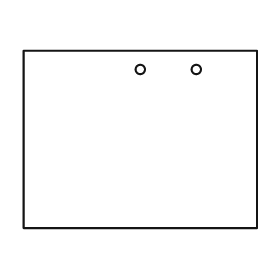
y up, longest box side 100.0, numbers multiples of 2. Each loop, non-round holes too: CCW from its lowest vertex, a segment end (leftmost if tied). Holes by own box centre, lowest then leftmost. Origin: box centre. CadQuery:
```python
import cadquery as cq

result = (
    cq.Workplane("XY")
    .moveTo(-50.0, -38.0)
    .lineTo(50.0, -38.0)
    .lineTo(50.0, 38.0)
    .lineTo(-50.0, 38.0)
    .close()
    .moveTo(0.0, 30.0)
    .circle(2.0)
    .moveTo(24.0, 30.0)
    .circle(2.0)
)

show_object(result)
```